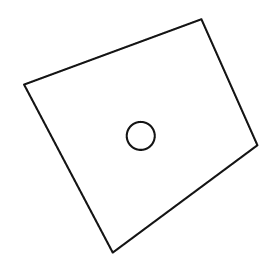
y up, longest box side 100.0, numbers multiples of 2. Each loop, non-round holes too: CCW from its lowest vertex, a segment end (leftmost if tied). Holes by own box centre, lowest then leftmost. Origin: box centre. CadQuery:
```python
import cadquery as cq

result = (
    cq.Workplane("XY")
    .moveTo(-12.0, -50.0)
    .lineTo(50.0, -4.0)
    .lineTo(26.0, 50.0)
    .lineTo(-50.0, 22.0)
    .close()
    .moveTo(0.0, 0.0)
    .circle(6.0)
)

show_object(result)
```